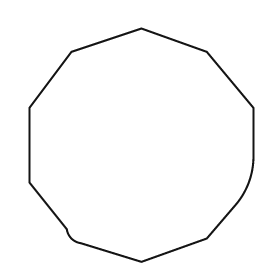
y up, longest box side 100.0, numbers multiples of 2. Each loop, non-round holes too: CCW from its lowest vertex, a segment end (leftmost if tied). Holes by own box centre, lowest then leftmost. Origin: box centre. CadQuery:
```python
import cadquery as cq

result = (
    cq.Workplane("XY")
    .moveTo(0.0, -50.0)
    .lineTo(28.0, -40.0)
    .lineTo(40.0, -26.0)
    .threePointArc((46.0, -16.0), (48.0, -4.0))
    .lineTo(48.0, 16.0)
    .lineTo(28.0, 40.0)
    .lineTo(0.0, 50.0)
    .lineTo(-30.0, 40.0)
    .lineTo(-48.0, 16.0)
    .lineTo(-48.0, -16.0)
    .lineTo(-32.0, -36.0)
    .threePointArc((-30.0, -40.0), (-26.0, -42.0))
    .close()
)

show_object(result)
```